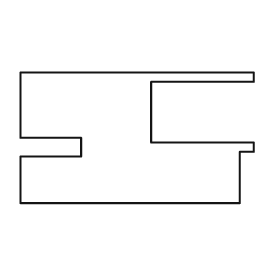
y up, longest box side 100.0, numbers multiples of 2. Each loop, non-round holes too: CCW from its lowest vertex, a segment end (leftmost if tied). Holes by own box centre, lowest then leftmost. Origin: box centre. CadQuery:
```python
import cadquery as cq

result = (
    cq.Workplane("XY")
    .moveTo(-50.0, -28.0)
    .lineTo(44.0, -28.0)
    .lineTo(44.0, -6.0)
    .lineTo(50.0, -6.0)
    .lineTo(50.0, -2.0)
    .lineTo(6.0, -2.0)
    .lineTo(6.0, 24.0)
    .lineTo(50.0, 24.0)
    .lineTo(50.0, 28.0)
    .lineTo(-50.0, 28.0)
    .lineTo(-50.0, 0.0)
    .lineTo(-24.0, 0.0)
    .lineTo(-24.0, -8.0)
    .lineTo(-50.0, -8.0)
    .close()
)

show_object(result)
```